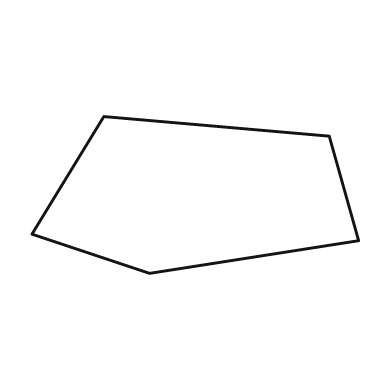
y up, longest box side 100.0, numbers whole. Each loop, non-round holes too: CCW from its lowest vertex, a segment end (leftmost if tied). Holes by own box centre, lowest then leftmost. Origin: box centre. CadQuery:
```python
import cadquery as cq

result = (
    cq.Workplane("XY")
    .moveTo(-14.0, -24.0)
    .lineTo(50.0, -14.0)
    .lineTo(41.0, 18.0)
    .lineTo(-28.0, 24.0)
    .lineTo(-50.0, -12.0)
    .close()
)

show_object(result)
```